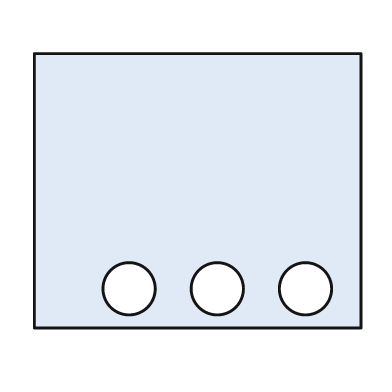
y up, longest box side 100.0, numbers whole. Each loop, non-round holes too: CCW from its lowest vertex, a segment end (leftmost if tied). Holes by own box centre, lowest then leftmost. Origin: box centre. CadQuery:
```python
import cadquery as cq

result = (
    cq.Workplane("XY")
    .moveTo(-50.0, -42.0)
    .lineTo(50.0, -42.0)
    .lineTo(50.0, 42.0)
    .lineTo(-50.0, 42.0)
    .close()
    .moveTo(-21.0, -30.0)
    .circle(8.0)
    .moveTo(6.0, -30.0)
    .circle(8.0)
    .moveTo(33.0, -30.0)
    .circle(8.0)
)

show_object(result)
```